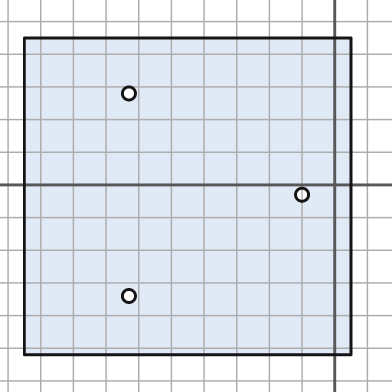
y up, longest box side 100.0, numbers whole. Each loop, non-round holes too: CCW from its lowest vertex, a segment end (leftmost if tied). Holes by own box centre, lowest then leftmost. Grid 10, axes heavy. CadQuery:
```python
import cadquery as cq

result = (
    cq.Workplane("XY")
    .moveTo(-95.0, -52.0)
    .lineTo(5.0, -52.0)
    .lineTo(5.0, 45.0)
    .lineTo(-95.0, 45.0)
    .close()
    .moveTo(-63.0, -34.0)
    .circle(2.0)
    .moveTo(-10.0, -3.0)
    .circle(2.0)
    .moveTo(-63.0, 28.0)
    .circle(2.0)
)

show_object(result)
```